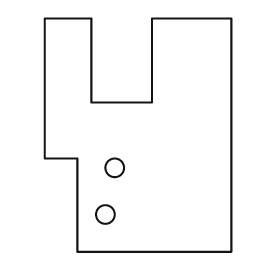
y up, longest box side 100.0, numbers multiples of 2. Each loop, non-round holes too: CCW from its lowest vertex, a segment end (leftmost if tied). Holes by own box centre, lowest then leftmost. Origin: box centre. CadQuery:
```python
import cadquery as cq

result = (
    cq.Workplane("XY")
    .moveTo(-26.0, -50.0)
    .lineTo(40.0, -50.0)
    .lineTo(40.0, 50.0)
    .lineTo(6.0, 50.0)
    .lineTo(6.0, 14.0)
    .lineTo(-20.0, 14.0)
    .lineTo(-20.0, 50.0)
    .lineTo(-40.0, 50.0)
    .lineTo(-40.0, -10.0)
    .lineTo(-26.0, -10.0)
    .close()
    .moveTo(-14.0, -34.0)
    .circle(4.0)
    .moveTo(-10.0, -14.0)
    .circle(4.0)
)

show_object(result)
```